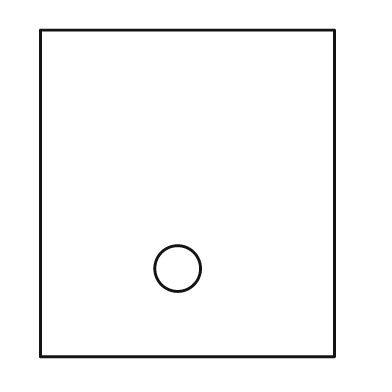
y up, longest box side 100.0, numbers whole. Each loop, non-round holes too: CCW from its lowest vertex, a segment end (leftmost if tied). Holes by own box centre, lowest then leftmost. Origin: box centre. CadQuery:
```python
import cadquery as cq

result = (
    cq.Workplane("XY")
    .moveTo(-45.0, -50.0)
    .lineTo(45.0, -50.0)
    .lineTo(45.0, 50.0)
    .lineTo(-45.0, 50.0)
    .close()
    .moveTo(-3.0, -23.0)
    .circle(7.0)
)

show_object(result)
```